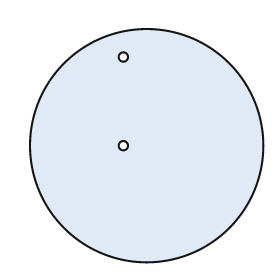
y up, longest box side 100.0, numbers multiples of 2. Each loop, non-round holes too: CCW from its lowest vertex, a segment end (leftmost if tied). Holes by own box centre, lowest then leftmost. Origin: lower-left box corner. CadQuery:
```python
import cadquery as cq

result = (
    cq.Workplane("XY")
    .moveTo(50.0, 50.0)
    .circle(50.0)
    .moveTo(40.0, 50.0)
    .circle(2.0)
    .moveTo(40.0, 88.0)
    .circle(2.0)
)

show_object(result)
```